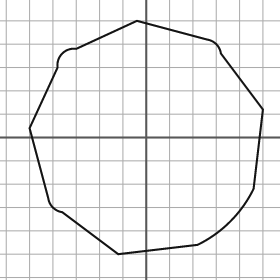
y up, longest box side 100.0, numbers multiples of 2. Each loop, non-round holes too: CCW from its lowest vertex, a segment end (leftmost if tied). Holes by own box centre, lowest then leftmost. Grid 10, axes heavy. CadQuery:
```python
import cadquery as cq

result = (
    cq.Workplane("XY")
    .moveTo(-12.0, -50.0)
    .lineTo(22.0, -46.0)
    .threePointArc((36.0, -36.0), (46.0, -22.0))
    .lineTo(50.0, 12.0)
    .lineTo(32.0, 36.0)
    .threePointArc((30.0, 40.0), (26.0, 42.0))
    .lineTo(-4.0, 50.0)
    .lineTo(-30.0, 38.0)
    .threePointArc((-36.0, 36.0), (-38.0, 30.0))
    .lineTo(-50.0, 4.0)
    .lineTo(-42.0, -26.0)
    .threePointArc((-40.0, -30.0), (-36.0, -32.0))
    .close()
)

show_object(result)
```